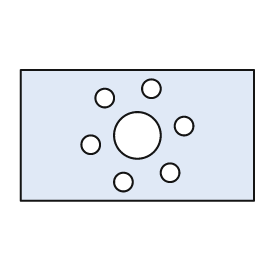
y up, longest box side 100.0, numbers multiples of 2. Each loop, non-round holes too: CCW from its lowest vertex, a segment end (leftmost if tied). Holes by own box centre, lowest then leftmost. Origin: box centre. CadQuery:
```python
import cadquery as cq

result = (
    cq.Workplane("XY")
    .moveTo(-50.0, -28.0)
    .lineTo(50.0, -28.0)
    .lineTo(50.0, 28.0)
    .lineTo(-50.0, 28.0)
    .close()
    .moveTo(-6.0, -20.0)
    .circle(4.0)
    .moveTo(14.0, -16.0)
    .circle(4.0)
    .moveTo(-20.0, -4.0)
    .circle(4.0)
    .moveTo(0.0, 0.0)
    .circle(10.0)
    .moveTo(20.0, 4.0)
    .circle(4.0)
    .moveTo(-14.0, 16.0)
    .circle(4.0)
    .moveTo(6.0, 20.0)
    .circle(4.0)
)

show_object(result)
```